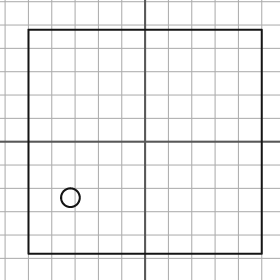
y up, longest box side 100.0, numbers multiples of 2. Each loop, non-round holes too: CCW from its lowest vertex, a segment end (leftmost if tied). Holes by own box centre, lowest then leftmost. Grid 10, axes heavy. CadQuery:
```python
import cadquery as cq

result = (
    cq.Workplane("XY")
    .moveTo(-50.0, -48.0)
    .lineTo(50.0, -48.0)
    .lineTo(50.0, 48.0)
    .lineTo(-50.0, 48.0)
    .close()
    .moveTo(-32.0, -24.0)
    .circle(4.0)
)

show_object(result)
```